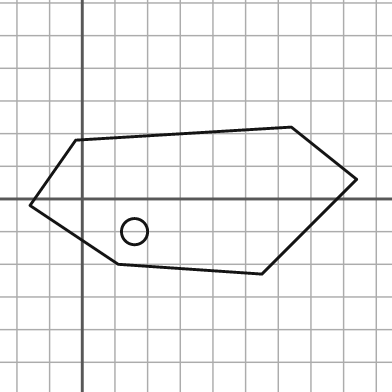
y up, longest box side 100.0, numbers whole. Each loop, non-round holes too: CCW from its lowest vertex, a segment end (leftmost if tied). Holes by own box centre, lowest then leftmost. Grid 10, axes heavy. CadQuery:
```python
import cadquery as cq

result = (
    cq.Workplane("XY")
    .moveTo(55.0, -23.0)
    .lineTo(84.0, 6.0)
    .lineTo(64.0, 22.0)
    .lineTo(-2.0, 18.0)
    .lineTo(-16.0, -2.0)
    .lineTo(11.0, -20.0)
    .close()
    .moveTo(16.0, -10.0)
    .circle(4.0)
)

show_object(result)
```